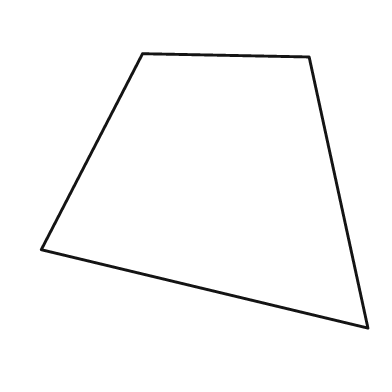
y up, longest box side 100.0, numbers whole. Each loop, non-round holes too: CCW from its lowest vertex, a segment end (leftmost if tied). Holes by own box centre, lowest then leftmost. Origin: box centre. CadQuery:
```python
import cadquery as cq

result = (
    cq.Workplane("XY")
    .moveTo(50.0, -42.0)
    .lineTo(32.0, 41.0)
    .lineTo(-19.0, 42.0)
    .lineTo(-50.0, -18.0)
    .close()
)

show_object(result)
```